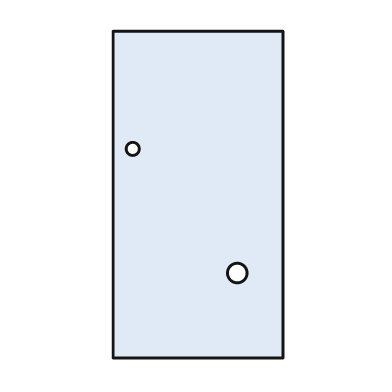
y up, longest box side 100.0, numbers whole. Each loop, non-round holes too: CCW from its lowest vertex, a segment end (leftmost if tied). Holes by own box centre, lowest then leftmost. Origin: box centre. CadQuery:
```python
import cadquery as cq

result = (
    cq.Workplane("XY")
    .moveTo(-26.0, -50.0)
    .lineTo(26.0, -50.0)
    .lineTo(26.0, 50.0)
    .lineTo(-26.0, 50.0)
    .close()
    .moveTo(12.0, -24.0)
    .circle(3.0)
    .moveTo(-20.0, 14.0)
    .circle(2.0)
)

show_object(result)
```